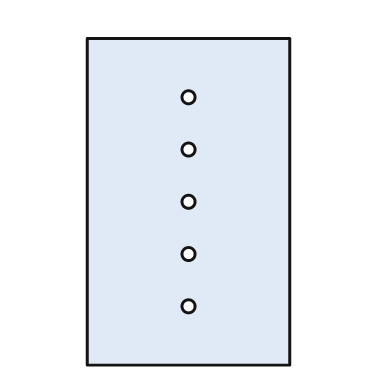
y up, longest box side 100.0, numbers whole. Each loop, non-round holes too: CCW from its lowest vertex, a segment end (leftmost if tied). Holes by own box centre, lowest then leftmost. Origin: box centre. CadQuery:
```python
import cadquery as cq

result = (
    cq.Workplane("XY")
    .moveTo(-31.0, -50.0)
    .lineTo(31.0, -50.0)
    .lineTo(31.0, 50.0)
    .lineTo(-31.0, 50.0)
    .close()
    .moveTo(0.0, -32.0)
    .circle(2.0)
    .moveTo(0.0, -16.0)
    .circle(2.0)
    .moveTo(0.0, 0.0)
    .circle(2.0)
    .moveTo(0.0, 16.0)
    .circle(2.0)
    .moveTo(0.0, 32.0)
    .circle(2.0)
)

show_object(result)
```